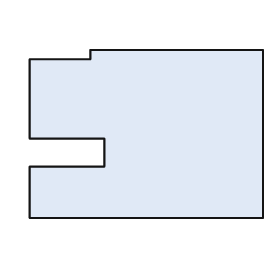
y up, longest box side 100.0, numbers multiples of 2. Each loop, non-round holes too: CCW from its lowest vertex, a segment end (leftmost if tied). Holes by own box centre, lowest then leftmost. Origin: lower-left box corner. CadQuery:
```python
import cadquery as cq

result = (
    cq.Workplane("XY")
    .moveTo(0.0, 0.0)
    .lineTo(100.0, 0.0)
    .lineTo(100.0, 72.0)
    .lineTo(26.0, 72.0)
    .lineTo(26.0, 68.0)
    .lineTo(0.0, 68.0)
    .lineTo(0.0, 34.0)
    .lineTo(32.0, 34.0)
    .lineTo(32.0, 22.0)
    .lineTo(0.0, 22.0)
    .close()
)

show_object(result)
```